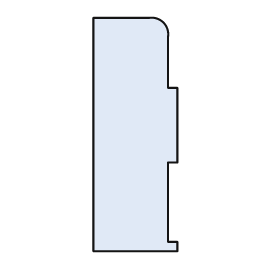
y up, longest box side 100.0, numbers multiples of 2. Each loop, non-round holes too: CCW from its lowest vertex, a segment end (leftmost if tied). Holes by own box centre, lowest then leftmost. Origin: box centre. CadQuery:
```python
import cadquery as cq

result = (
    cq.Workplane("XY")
    .moveTo(-18.0, -50.0)
    .lineTo(18.0, -50.0)
    .lineTo(18.0, -46.0)
    .lineTo(14.0, -46.0)
    .lineTo(14.0, -12.0)
    .lineTo(18.0, -12.0)
    .lineTo(18.0, 20.0)
    .lineTo(14.0, 20.0)
    .lineTo(14.0, 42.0)
    .threePointArc((12.0, 48.0), (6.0, 50.0))
    .lineTo(-18.0, 50.0)
    .close()
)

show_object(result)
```